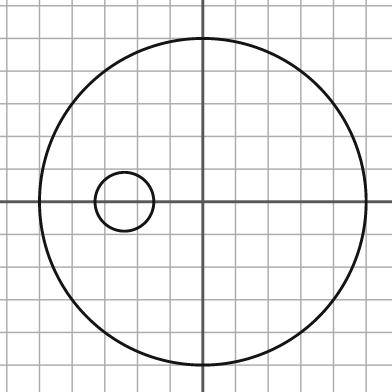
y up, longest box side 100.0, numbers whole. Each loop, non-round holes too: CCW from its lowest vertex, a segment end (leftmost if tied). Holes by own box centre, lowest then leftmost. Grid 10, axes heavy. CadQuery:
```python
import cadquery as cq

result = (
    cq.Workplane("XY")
    .moveTo(0.0, 0.0)
    .circle(50.0)
    .moveTo(-24.0, 0.0)
    .circle(9.0)
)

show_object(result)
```